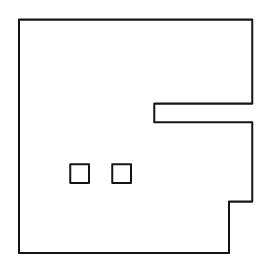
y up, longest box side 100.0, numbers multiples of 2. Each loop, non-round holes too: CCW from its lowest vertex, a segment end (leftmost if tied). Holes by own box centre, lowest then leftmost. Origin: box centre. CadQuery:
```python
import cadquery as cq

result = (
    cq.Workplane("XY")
    .moveTo(-50.0, -50.0)
    .lineTo(40.0, -50.0)
    .lineTo(40.0, -28.0)
    .lineTo(50.0, -28.0)
    .lineTo(50.0, 6.0)
    .lineTo(8.0, 6.0)
    .lineTo(8.0, 14.0)
    .lineTo(50.0, 14.0)
    .lineTo(50.0, 50.0)
    .lineTo(-50.0, 50.0)
    .close()
    .moveTo(-28.0, -20.0)
    .lineTo(-20.0, -20.0)
    .lineTo(-20.0, -12.0)
    .lineTo(-28.0, -12.0)
    .close()
    .moveTo(-10.0, -20.0)
    .lineTo(-2.0, -20.0)
    .lineTo(-2.0, -12.0)
    .lineTo(-10.0, -12.0)
    .close()
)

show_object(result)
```